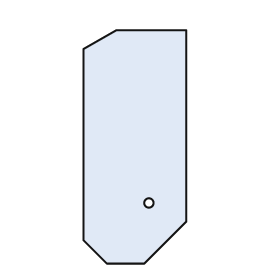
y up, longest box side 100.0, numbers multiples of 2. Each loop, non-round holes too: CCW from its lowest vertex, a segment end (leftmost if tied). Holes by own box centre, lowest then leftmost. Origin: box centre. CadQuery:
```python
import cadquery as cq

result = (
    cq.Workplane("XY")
    .moveTo(-12.0, -50.0)
    .lineTo(4.0, -50.0)
    .lineTo(22.0, -32.0)
    .lineTo(22.0, 50.0)
    .lineTo(-8.0, 50.0)
    .lineTo(-22.0, 42.0)
    .lineTo(-22.0, -40.0)
    .close()
    .moveTo(6.0, -24.0)
    .circle(2.0)
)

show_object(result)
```